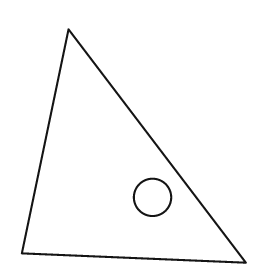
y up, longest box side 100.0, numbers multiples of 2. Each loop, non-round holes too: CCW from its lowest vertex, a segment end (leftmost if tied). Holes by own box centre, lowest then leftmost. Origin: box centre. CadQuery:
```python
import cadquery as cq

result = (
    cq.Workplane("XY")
    .moveTo(48.0, -50.0)
    .lineTo(-28.0, 50.0)
    .lineTo(-48.0, -46.0)
    .close()
    .moveTo(8.0, -22.0)
    .circle(8.0)
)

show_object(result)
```